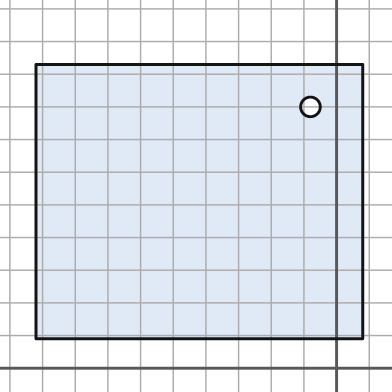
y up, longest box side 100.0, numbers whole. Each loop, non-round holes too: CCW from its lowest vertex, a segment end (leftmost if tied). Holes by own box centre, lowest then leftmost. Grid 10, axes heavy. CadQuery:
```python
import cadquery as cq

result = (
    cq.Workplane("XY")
    .moveTo(-92.0, 9.0)
    .lineTo(8.0, 9.0)
    .lineTo(8.0, 93.0)
    .lineTo(-92.0, 93.0)
    .close()
    .moveTo(-8.0, 80.0)
    .circle(3.0)
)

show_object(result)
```